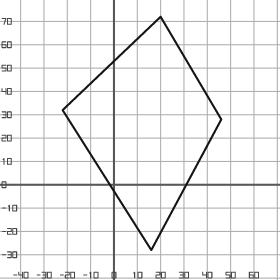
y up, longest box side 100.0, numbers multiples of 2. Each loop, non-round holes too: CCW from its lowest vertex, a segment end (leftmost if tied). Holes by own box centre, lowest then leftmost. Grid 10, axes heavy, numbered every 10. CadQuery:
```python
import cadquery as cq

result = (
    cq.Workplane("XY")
    .moveTo(16.0, -28.0)
    .lineTo(46.0, 28.0)
    .lineTo(20.0, 72.0)
    .lineTo(-22.0, 32.0)
    .close()
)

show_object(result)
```